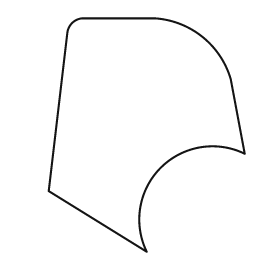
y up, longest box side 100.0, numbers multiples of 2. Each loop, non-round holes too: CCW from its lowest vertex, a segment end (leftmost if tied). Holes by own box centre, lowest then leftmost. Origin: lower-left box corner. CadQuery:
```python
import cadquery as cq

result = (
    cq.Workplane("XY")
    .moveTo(42.0, 0.0)
    .threePointArc((48.0, 36.0), (84.0, 42.0))
    .lineTo(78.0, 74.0)
    .threePointArc((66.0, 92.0), (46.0, 100.0))
    .lineTo(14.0, 100.0)
    .threePointArc((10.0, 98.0), (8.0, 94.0))
    .lineTo(0.0, 26.0)
    .close()
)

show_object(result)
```